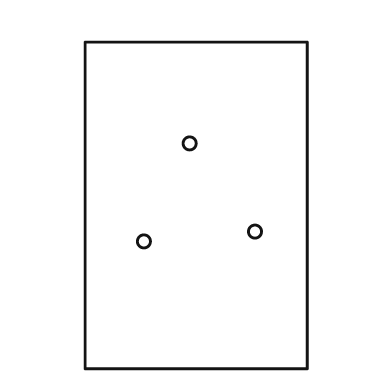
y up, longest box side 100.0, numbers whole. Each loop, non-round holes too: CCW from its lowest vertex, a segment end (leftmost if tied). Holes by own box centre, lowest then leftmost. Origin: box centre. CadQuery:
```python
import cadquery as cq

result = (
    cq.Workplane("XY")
    .moveTo(-34.0, -50.0)
    .lineTo(34.0, -50.0)
    .lineTo(34.0, 50.0)
    .lineTo(-34.0, 50.0)
    .close()
    .moveTo(-16.0, -11.0)
    .circle(2.0)
    .moveTo(18.0, -8.0)
    .circle(2.0)
    .moveTo(-2.0, 19.0)
    .circle(2.0)
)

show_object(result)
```